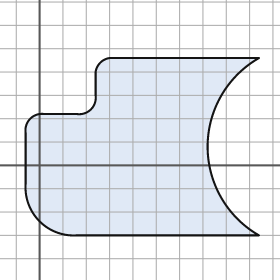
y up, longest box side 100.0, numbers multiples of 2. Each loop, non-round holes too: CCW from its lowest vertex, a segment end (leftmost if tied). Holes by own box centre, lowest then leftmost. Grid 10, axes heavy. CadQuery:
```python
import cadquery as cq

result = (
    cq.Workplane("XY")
    .moveTo(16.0, -30.0)
    .lineTo(94.0, -30.0)
    .threePointArc((72.0, 8.0), (94.0, 46.0))
    .lineTo(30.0, 46.0)
    .threePointArc((26.0, 44.0), (24.0, 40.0))
    .lineTo(24.0, 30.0)
    .threePointArc((22.0, 24.0), (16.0, 22.0))
    .lineTo(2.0, 22.0)
    .threePointArc((-4.0, 20.0), (-6.0, 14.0))
    .lineTo(-6.0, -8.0)
    .threePointArc((0.0, -24.0), (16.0, -30.0))
    .close()
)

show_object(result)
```